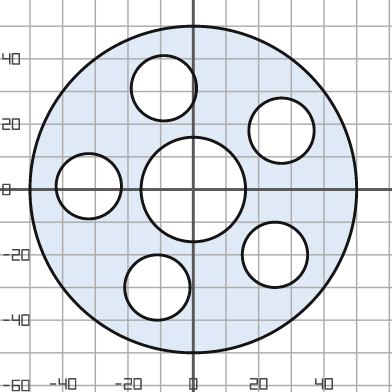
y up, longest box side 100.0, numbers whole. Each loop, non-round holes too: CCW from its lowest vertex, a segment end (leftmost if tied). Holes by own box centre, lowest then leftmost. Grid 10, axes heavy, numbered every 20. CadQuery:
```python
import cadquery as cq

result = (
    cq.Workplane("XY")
    .moveTo(0.0, 0.0)
    .circle(50.0)
    .moveTo(-11.0, -30.0)
    .circle(10.0)
    .moveTo(25.0, -20.0)
    .circle(10.0)
    .moveTo(0.0, 0.0)
    .circle(16.0)
    .moveTo(-32.0, 1.0)
    .circle(10.0)
    .moveTo(27.0, 18.0)
    .circle(10.0)
    .moveTo(-9.0, 31.0)
    .circle(10.0)
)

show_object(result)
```